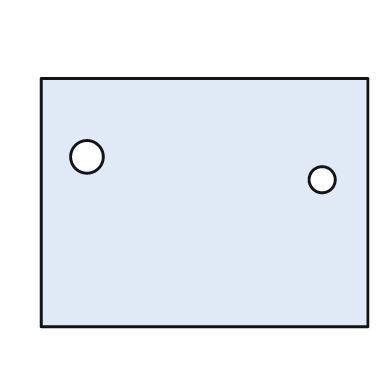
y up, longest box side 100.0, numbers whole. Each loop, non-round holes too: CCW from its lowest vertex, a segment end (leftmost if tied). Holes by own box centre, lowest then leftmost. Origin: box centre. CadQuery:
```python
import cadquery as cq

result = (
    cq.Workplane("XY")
    .moveTo(-50.0, -38.0)
    .lineTo(50.0, -38.0)
    .lineTo(50.0, 38.0)
    .lineTo(-50.0, 38.0)
    .close()
    .moveTo(36.0, 7.0)
    .circle(4.0)
    .moveTo(-36.0, 14.0)
    .circle(5.0)
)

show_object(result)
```